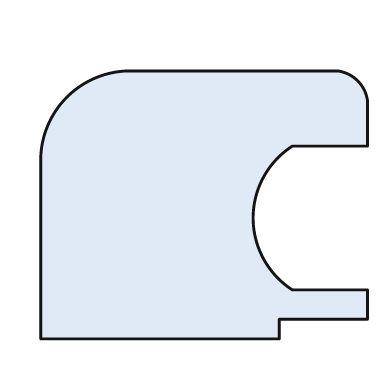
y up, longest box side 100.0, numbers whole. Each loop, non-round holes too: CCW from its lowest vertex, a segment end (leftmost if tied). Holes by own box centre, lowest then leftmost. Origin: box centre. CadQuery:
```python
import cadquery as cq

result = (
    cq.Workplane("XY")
    .moveTo(-50.0, -41.0)
    .lineTo(23.0, -41.0)
    .lineTo(23.0, -35.0)
    .lineTo(50.0, -35.0)
    .lineTo(50.0, -26.0)
    .lineTo(27.0, -26.0)
    .threePointArc((15.0, -4.0), (27.0, 18.0))
    .lineTo(50.0, 18.0)
    .lineTo(50.0, 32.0)
    .threePointArc((47.0, 38.0), (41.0, 41.0))
    .lineTo(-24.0, 41.0)
    .threePointArc((-42.0, 33.0), (-50.0, 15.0))
    .close()
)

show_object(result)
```